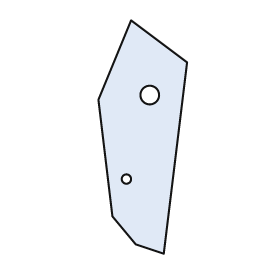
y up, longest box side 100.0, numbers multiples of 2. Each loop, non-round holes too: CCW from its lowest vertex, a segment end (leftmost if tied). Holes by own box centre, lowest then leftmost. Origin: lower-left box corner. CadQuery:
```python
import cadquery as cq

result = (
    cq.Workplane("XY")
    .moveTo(28.0, 0.0)
    .lineTo(38.0, 82.0)
    .lineTo(14.0, 100.0)
    .lineTo(0.0, 66.0)
    .lineTo(6.0, 16.0)
    .lineTo(16.0, 4.0)
    .close()
    .moveTo(12.0, 32.0)
    .circle(2.0)
    .moveTo(22.0, 68.0)
    .circle(4.0)
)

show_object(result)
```